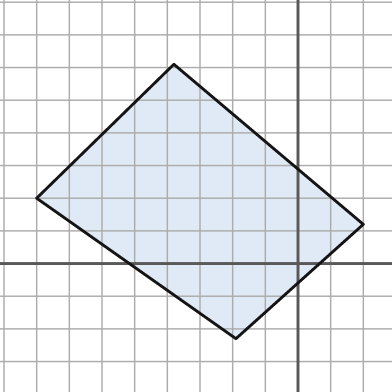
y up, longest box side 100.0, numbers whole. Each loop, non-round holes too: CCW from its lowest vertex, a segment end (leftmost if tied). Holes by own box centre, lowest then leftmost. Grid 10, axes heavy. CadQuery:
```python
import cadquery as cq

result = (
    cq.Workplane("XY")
    .moveTo(-19.0, -23.0)
    .lineTo(20.0, 12.0)
    .lineTo(-38.0, 61.0)
    .lineTo(-80.0, 20.0)
    .close()
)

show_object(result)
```